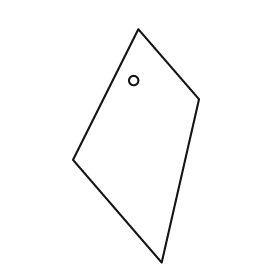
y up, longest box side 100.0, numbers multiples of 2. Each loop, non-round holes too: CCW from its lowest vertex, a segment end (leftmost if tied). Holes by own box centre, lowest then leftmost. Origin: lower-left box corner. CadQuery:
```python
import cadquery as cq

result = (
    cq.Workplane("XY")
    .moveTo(38.0, 0.0)
    .lineTo(54.0, 70.0)
    .lineTo(28.0, 100.0)
    .lineTo(0.0, 44.0)
    .close()
    .moveTo(26.0, 78.0)
    .circle(2.0)
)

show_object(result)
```